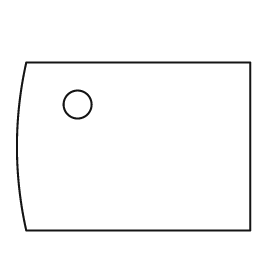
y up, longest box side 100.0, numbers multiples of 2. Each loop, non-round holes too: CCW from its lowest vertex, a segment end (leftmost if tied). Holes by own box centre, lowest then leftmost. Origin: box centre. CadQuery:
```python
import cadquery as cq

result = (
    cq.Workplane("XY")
    .moveTo(-46.0, -36.0)
    .lineTo(50.0, -36.0)
    .lineTo(50.0, 36.0)
    .lineTo(-46.0, 36.0)
    .threePointArc((-50.0, 0.0), (-46.0, -36.0))
    .close()
    .moveTo(-24.0, 18.0)
    .circle(6.0)
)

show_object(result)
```